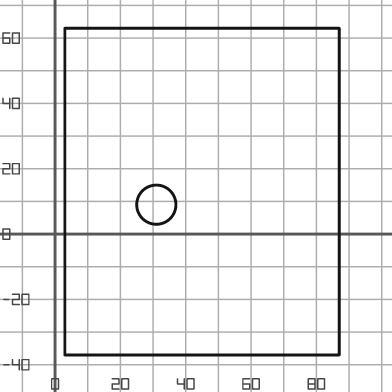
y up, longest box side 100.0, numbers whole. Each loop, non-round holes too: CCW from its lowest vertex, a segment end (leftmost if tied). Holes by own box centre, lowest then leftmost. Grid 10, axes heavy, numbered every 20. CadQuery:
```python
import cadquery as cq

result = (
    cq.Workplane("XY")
    .moveTo(3.0, -37.0)
    .lineTo(87.0, -37.0)
    .lineTo(87.0, 63.0)
    .lineTo(3.0, 63.0)
    .close()
    .moveTo(31.0, 9.0)
    .circle(6.0)
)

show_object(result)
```